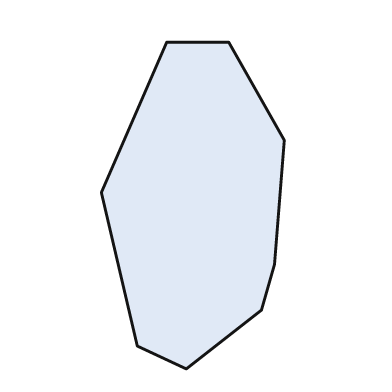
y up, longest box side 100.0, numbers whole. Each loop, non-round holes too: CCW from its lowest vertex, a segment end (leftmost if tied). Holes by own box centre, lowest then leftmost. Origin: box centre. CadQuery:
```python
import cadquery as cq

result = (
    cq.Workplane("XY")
    .moveTo(-2.0, -50.0)
    .lineTo(21.0, -32.0)
    .lineTo(25.0, -18.0)
    .lineTo(28.0, 20.0)
    .lineTo(11.0, 50.0)
    .lineTo(-8.0, 50.0)
    .lineTo(-28.0, 4.0)
    .lineTo(-17.0, -43.0)
    .close()
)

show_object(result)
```